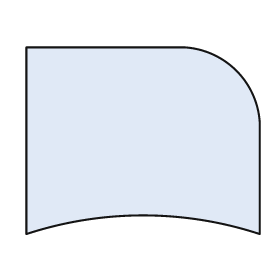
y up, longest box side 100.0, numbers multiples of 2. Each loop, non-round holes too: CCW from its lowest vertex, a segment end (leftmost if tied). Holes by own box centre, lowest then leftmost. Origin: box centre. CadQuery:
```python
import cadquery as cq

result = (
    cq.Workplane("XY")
    .moveTo(-50.0, -40.0)
    .threePointArc((0.0, -32.0), (50.0, -40.0))
    .lineTo(50.0, 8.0)
    .threePointArc((40.0, 30.0), (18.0, 40.0))
    .lineTo(-50.0, 40.0)
    .close()
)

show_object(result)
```